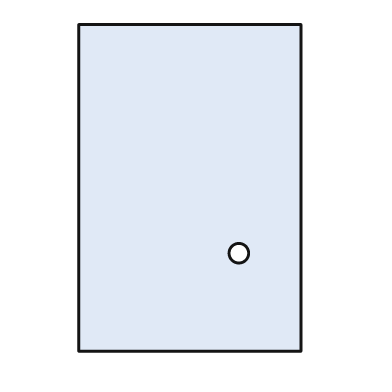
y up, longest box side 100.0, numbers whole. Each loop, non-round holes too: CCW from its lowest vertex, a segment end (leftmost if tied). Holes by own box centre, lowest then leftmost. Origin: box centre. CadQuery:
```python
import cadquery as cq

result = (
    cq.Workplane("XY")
    .moveTo(-34.0, -50.0)
    .lineTo(34.0, -50.0)
    .lineTo(34.0, 50.0)
    .lineTo(-34.0, 50.0)
    .close()
    .moveTo(15.0, -20.0)
    .circle(3.0)
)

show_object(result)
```